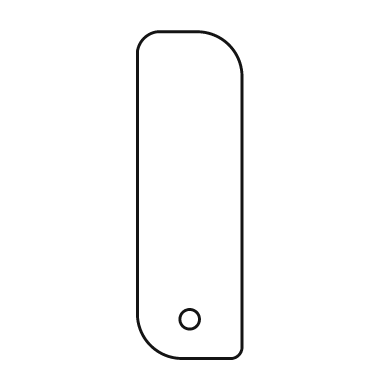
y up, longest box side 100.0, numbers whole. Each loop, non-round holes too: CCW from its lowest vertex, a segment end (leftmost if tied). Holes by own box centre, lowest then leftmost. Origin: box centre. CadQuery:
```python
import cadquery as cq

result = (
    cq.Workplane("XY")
    .moveTo(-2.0, -50.0)
    .lineTo(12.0, -50.0)
    .threePointArc((15.0, -49.0), (16.0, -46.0))
    .lineTo(16.0, 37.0)
    .threePointArc((12.0, 46.0), (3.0, 50.0))
    .lineTo(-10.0, 50.0)
    .threePointArc((-14.0, 48.0), (-16.0, 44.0))
    .lineTo(-16.0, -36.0)
    .threePointArc((-12.0, -46.0), (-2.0, -50.0))
    .close()
    .moveTo(0.0, -38.0)
    .circle(3.0)
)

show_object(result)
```